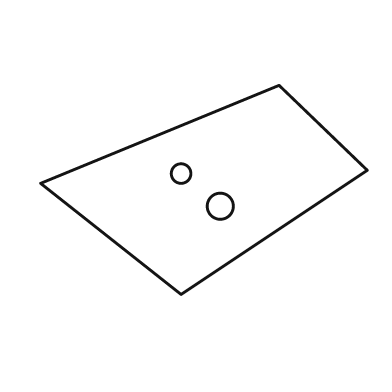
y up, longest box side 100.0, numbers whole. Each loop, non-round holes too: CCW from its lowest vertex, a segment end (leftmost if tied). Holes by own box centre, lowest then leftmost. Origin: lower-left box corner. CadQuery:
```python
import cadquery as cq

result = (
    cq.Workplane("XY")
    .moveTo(43.0, 0.0)
    .lineTo(100.0, 38.0)
    .lineTo(73.0, 64.0)
    .lineTo(0.0, 34.0)
    .close()
    .moveTo(55.0, 27.0)
    .circle(4.0)
    .moveTo(43.0, 37.0)
    .circle(3.0)
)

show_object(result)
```